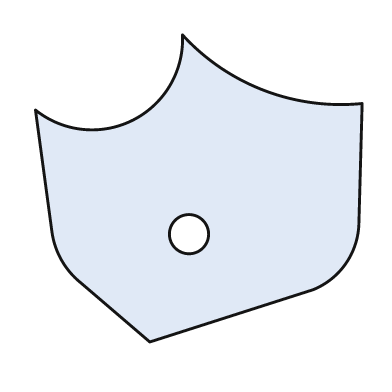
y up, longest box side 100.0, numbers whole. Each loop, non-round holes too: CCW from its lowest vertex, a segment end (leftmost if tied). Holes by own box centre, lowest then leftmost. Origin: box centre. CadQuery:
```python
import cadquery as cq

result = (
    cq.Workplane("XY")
    .moveTo(-15.0, -47.0)
    .lineTo(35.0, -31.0)
    .threePointArc((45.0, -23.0), (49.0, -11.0))
    .lineTo(50.0, 26.0)
    .threePointArc((20.0, 30.0), (-5.0, 47.0))
    .threePointArc((-20.0, 21.0), (-50.0, 24.0))
    .lineTo(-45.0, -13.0)
    .threePointArc((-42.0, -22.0), (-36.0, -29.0))
    .close()
    .moveTo(-3.0, -14.0)
    .circle(6.0)
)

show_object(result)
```